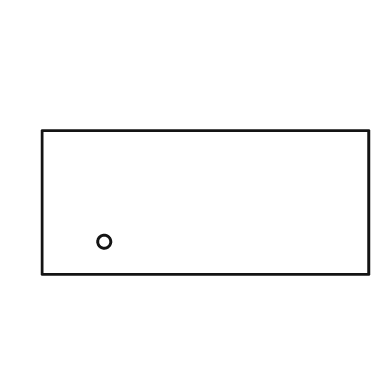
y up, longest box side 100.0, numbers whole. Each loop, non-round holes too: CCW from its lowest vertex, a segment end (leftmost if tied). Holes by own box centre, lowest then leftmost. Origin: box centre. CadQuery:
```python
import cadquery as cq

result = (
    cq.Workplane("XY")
    .moveTo(-50.0, -22.0)
    .lineTo(50.0, -22.0)
    .lineTo(50.0, 22.0)
    .lineTo(-50.0, 22.0)
    .close()
    .moveTo(-31.0, -12.0)
    .circle(2.0)
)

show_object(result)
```